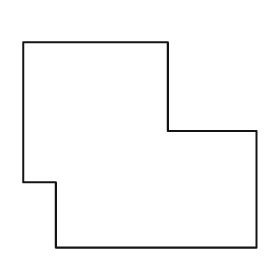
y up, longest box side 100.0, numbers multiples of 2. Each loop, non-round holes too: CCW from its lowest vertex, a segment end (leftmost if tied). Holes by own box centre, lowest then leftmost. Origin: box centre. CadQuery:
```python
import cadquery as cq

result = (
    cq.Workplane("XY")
    .moveTo(-36.0, -44.0)
    .lineTo(50.0, -44.0)
    .lineTo(50.0, 6.0)
    .lineTo(12.0, 6.0)
    .lineTo(12.0, 44.0)
    .lineTo(-50.0, 44.0)
    .lineTo(-50.0, -16.0)
    .lineTo(-36.0, -16.0)
    .close()
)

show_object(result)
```